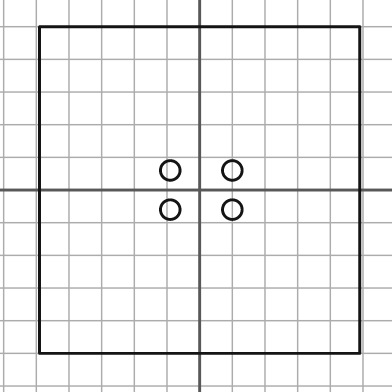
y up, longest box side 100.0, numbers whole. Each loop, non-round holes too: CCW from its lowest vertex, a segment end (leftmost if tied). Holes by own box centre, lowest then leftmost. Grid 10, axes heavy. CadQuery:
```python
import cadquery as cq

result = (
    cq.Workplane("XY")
    .moveTo(-49.0, -50.0)
    .lineTo(49.0, -50.0)
    .lineTo(49.0, 50.0)
    .lineTo(-49.0, 50.0)
    .close()
    .moveTo(-9.0, -6.0)
    .circle(3.0)
    .moveTo(10.0, -6.0)
    .circle(3.0)
    .moveTo(-9.0, 6.0)
    .circle(3.0)
    .moveTo(10.0, 6.0)
    .circle(3.0)
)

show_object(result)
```